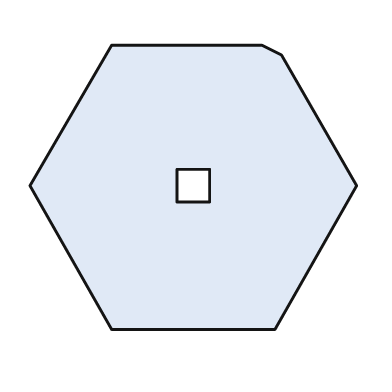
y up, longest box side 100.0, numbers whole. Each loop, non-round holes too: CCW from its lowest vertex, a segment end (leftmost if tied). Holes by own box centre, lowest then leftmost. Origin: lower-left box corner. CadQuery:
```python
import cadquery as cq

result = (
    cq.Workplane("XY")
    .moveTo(25.0, 0.0)
    .lineTo(75.0, 0.0)
    .lineTo(100.0, 44.0)
    .lineTo(77.0, 84.0)
    .lineTo(71.0, 87.0)
    .lineTo(25.0, 87.0)
    .lineTo(0.0, 44.0)
    .close()
    .moveTo(45.0, 39.0)
    .lineTo(55.0, 39.0)
    .lineTo(55.0, 49.0)
    .lineTo(45.0, 49.0)
    .close()
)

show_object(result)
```